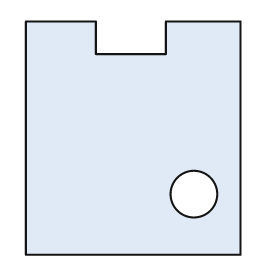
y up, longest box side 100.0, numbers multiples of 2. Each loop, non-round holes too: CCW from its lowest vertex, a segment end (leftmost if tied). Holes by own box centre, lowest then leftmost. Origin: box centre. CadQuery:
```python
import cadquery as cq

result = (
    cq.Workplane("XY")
    .moveTo(-46.0, -50.0)
    .lineTo(46.0, -50.0)
    .lineTo(46.0, 50.0)
    .lineTo(14.0, 50.0)
    .lineTo(14.0, 36.0)
    .lineTo(-16.0, 36.0)
    .lineTo(-16.0, 50.0)
    .lineTo(-46.0, 50.0)
    .close()
    .moveTo(26.0, -24.0)
    .circle(10.0)
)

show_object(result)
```